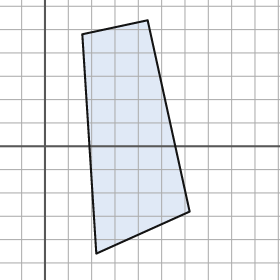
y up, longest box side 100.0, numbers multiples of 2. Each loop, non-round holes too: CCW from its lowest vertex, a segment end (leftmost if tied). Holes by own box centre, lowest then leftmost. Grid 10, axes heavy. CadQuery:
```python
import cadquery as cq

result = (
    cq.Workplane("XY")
    .moveTo(22.0, -46.0)
    .lineTo(62.0, -28.0)
    .lineTo(44.0, 54.0)
    .lineTo(16.0, 48.0)
    .close()
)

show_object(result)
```